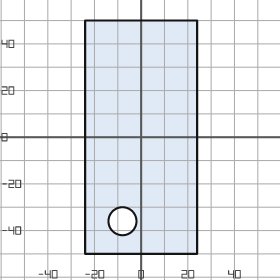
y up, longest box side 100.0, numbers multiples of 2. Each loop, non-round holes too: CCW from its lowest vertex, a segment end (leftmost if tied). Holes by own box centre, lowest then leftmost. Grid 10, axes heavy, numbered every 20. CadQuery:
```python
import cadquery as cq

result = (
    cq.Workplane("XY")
    .moveTo(-24.0, -50.0)
    .lineTo(24.0, -50.0)
    .lineTo(24.0, 50.0)
    .lineTo(-24.0, 50.0)
    .close()
    .moveTo(-8.0, -36.0)
    .circle(6.0)
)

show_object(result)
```